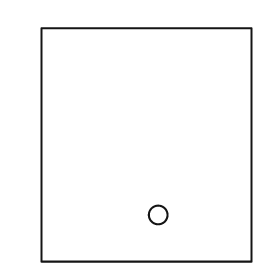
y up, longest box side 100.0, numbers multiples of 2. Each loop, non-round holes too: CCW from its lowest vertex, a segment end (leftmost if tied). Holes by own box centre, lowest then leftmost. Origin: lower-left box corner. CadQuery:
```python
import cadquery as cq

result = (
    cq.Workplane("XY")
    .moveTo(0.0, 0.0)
    .lineTo(90.0, 0.0)
    .lineTo(90.0, 100.0)
    .lineTo(0.0, 100.0)
    .close()
    .moveTo(50.0, 20.0)
    .circle(4.0)
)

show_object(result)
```